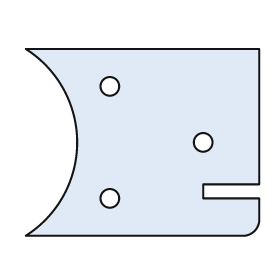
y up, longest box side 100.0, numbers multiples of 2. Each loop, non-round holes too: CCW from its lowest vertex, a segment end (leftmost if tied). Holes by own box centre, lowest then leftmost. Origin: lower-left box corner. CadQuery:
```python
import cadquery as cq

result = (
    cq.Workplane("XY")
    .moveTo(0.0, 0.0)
    .lineTo(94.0, 0.0)
    .threePointArc((98.0, 2.0), (100.0, 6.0))
    .lineTo(100.0, 16.0)
    .lineTo(76.0, 16.0)
    .lineTo(76.0, 22.0)
    .lineTo(100.0, 22.0)
    .lineTo(100.0, 80.0)
    .lineTo(0.0, 80.0)
    .threePointArc((22.0, 40.0), (0.0, 0.0))
    .close()
    .moveTo(36.0, 16.0)
    .circle(4.0)
    .moveTo(76.0, 40.0)
    .circle(4.0)
    .moveTo(36.0, 64.0)
    .circle(4.0)
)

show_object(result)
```